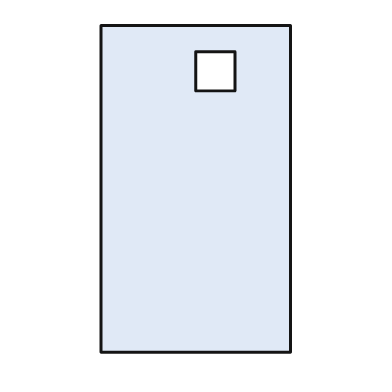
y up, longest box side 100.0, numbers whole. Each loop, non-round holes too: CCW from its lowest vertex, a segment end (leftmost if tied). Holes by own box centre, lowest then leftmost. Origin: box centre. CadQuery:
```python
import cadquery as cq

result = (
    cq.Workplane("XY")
    .moveTo(-29.0, -50.0)
    .lineTo(29.0, -50.0)
    .lineTo(29.0, 50.0)
    .lineTo(-29.0, 50.0)
    .close()
    .moveTo(0.0, 30.0)
    .lineTo(12.0, 30.0)
    .lineTo(12.0, 42.0)
    .lineTo(0.0, 42.0)
    .close()
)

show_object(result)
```